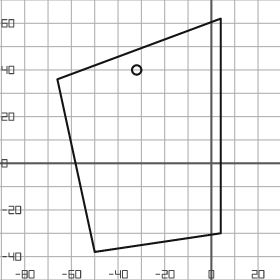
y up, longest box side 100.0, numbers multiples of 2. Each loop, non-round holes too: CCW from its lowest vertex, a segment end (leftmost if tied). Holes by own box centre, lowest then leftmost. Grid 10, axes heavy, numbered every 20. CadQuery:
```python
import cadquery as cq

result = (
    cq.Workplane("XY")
    .moveTo(-50.0, -38.0)
    .lineTo(4.0, -30.0)
    .lineTo(4.0, 62.0)
    .lineTo(-66.0, 36.0)
    .close()
    .moveTo(-32.0, 40.0)
    .circle(2.0)
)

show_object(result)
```